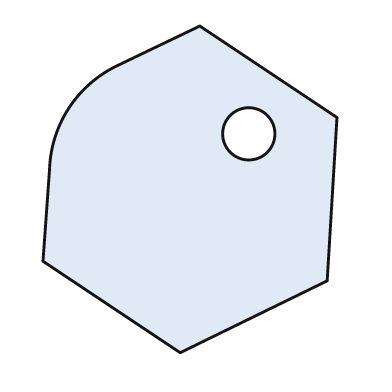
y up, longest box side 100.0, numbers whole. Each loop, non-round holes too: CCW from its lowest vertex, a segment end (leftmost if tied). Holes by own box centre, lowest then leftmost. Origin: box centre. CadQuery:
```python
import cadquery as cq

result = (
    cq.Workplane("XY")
    .moveTo(-3.0, -50.0)
    .lineTo(42.0, -28.0)
    .lineTo(45.0, 22.0)
    .lineTo(3.0, 50.0)
    .lineTo(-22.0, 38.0)
    .threePointArc((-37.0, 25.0), (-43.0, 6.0))
    .lineTo(-45.0, -22.0)
    .close()
    .moveTo(18.0, 17.0)
    .circle(8.0)
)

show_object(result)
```